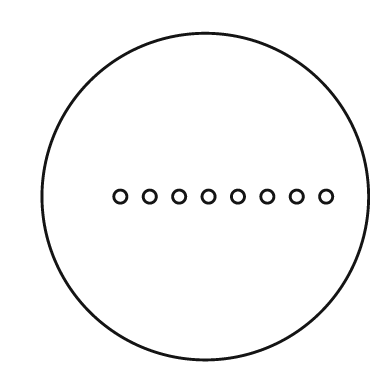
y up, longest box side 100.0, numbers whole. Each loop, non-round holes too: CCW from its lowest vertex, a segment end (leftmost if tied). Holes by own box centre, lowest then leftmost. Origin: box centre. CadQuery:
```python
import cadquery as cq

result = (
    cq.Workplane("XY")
    .moveTo(0.0, 0.0)
    .circle(50.0)
    .moveTo(-26.0, 0.0)
    .circle(2.0)
    .moveTo(-17.0, 0.0)
    .circle(2.0)
    .moveTo(-8.0, 0.0)
    .circle(2.0)
    .moveTo(1.0, 0.0)
    .circle(2.0)
    .moveTo(10.0, 0.0)
    .circle(2.0)
    .moveTo(19.0, 0.0)
    .circle(2.0)
    .moveTo(28.0, 0.0)
    .circle(2.0)
    .moveTo(37.0, 0.0)
    .circle(2.0)
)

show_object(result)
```